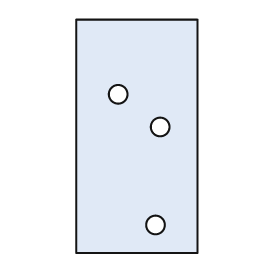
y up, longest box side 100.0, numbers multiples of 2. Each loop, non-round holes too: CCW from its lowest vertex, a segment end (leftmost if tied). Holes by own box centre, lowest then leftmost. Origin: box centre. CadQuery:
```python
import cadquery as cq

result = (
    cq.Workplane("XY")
    .moveTo(-26.0, -50.0)
    .lineTo(26.0, -50.0)
    .lineTo(26.0, 50.0)
    .lineTo(-26.0, 50.0)
    .close()
    .moveTo(8.0, -38.0)
    .circle(4.0)
    .moveTo(10.0, 4.0)
    .circle(4.0)
    .moveTo(-8.0, 18.0)
    .circle(4.0)
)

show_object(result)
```